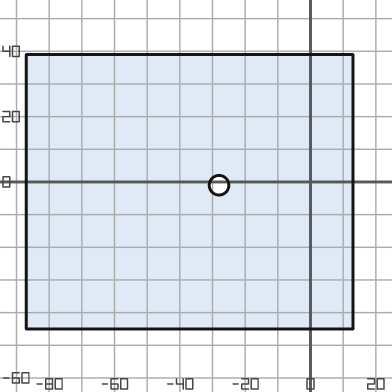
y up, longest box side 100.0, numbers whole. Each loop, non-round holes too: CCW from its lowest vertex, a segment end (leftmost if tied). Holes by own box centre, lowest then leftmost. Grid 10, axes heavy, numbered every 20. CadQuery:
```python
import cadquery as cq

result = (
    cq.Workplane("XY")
    .moveTo(-87.0, -45.0)
    .lineTo(13.0, -45.0)
    .lineTo(13.0, 39.0)
    .lineTo(-87.0, 39.0)
    .close()
    .moveTo(-28.0, -1.0)
    .circle(3.0)
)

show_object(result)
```